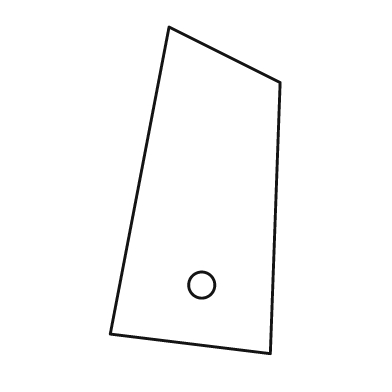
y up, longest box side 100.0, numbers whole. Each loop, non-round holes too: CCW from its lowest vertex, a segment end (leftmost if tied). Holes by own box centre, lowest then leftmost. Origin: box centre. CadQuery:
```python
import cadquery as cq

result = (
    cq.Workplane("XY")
    .moveTo(23.0, -50.0)
    .lineTo(26.0, 33.0)
    .lineTo(-8.0, 50.0)
    .lineTo(-26.0, -44.0)
    .close()
    .moveTo(2.0, -29.0)
    .circle(4.0)
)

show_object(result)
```